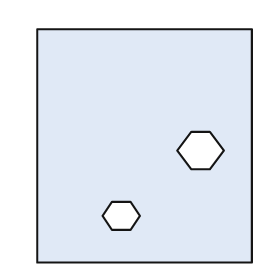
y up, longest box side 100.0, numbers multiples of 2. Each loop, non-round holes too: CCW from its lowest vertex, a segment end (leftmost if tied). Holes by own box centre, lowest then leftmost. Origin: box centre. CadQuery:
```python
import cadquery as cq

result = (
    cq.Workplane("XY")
    .moveTo(-46.0, -50.0)
    .lineTo(46.0, -50.0)
    .lineTo(46.0, 50.0)
    .lineTo(-46.0, 50.0)
    .close()
    .moveTo(-14.0, -36.0)
    .lineTo(-6.0, -36.0)
    .lineTo(-2.0, -30.0)
    .lineTo(-6.0, -24.0)
    .lineTo(-14.0, -24.0)
    .lineTo(-18.0, -30.0)
    .close()
    .moveTo(20.0, -10.0)
    .lineTo(28.0, -10.0)
    .lineTo(34.0, -2.0)
    .lineTo(28.0, 6.0)
    .lineTo(20.0, 6.0)
    .lineTo(14.0, -2.0)
    .close()
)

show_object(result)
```